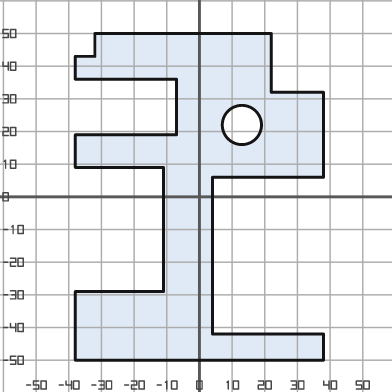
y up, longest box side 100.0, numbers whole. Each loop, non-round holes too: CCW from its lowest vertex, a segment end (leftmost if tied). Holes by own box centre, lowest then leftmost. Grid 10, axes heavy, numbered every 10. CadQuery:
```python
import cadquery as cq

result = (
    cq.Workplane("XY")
    .moveTo(-38.0, -50.0)
    .lineTo(38.0, -50.0)
    .lineTo(38.0, -42.0)
    .lineTo(4.0, -42.0)
    .lineTo(4.0, 6.0)
    .lineTo(38.0, 6.0)
    .lineTo(38.0, 32.0)
    .lineTo(22.0, 32.0)
    .lineTo(22.0, 50.0)
    .lineTo(-32.0, 50.0)
    .lineTo(-32.0, 43.0)
    .lineTo(-38.0, 43.0)
    .lineTo(-38.0, 36.0)
    .lineTo(-7.0, 36.0)
    .lineTo(-7.0, 19.0)
    .lineTo(-38.0, 19.0)
    .lineTo(-38.0, 9.0)
    .lineTo(-11.0, 9.0)
    .lineTo(-11.0, -29.0)
    .lineTo(-38.0, -29.0)
    .close()
    .moveTo(13.0, 22.0)
    .circle(6.0)
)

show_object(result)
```